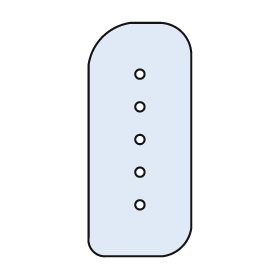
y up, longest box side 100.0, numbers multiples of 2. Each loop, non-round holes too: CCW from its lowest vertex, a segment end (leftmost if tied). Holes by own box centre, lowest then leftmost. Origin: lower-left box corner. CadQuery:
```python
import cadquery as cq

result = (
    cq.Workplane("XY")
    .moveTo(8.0, 0.0)
    .lineTo(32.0, 0.0)
    .threePointArc((40.0, 4.0), (44.0, 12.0))
    .lineTo(44.0, 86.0)
    .threePointArc((40.0, 96.0), (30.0, 100.0))
    .lineTo(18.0, 100.0)
    .threePointArc((6.0, 94.0), (0.0, 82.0))
    .lineTo(0.0, 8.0)
    .threePointArc((2.0, 2.0), (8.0, 0.0))
    .close()
    .moveTo(22.0, 22.0)
    .circle(2.0)
    .moveTo(22.0, 36.0)
    .circle(2.0)
    .moveTo(22.0, 50.0)
    .circle(2.0)
    .moveTo(22.0, 64.0)
    .circle(2.0)
    .moveTo(22.0, 78.0)
    .circle(2.0)
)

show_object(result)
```